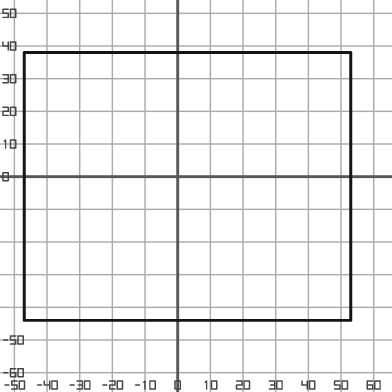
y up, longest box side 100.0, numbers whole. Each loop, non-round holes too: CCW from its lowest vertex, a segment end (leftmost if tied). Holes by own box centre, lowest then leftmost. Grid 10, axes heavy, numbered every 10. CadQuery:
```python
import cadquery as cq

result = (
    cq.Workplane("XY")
    .moveTo(-47.0, -44.0)
    .lineTo(53.0, -44.0)
    .lineTo(53.0, 38.0)
    .lineTo(-47.0, 38.0)
    .close()
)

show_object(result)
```